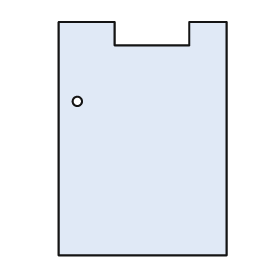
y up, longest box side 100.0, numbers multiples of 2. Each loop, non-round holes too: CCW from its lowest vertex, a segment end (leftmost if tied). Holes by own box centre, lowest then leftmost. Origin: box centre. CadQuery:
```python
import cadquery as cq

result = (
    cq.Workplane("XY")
    .moveTo(-36.0, -50.0)
    .lineTo(36.0, -50.0)
    .lineTo(36.0, 50.0)
    .lineTo(20.0, 50.0)
    .lineTo(20.0, 40.0)
    .lineTo(-12.0, 40.0)
    .lineTo(-12.0, 50.0)
    .lineTo(-36.0, 50.0)
    .close()
    .moveTo(-28.0, 16.0)
    .circle(2.0)
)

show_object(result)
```